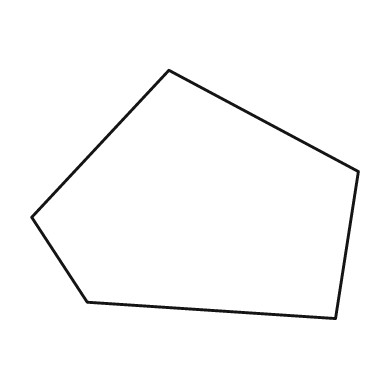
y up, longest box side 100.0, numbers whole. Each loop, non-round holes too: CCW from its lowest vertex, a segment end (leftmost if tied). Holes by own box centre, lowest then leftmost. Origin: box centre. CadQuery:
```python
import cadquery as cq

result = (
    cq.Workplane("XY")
    .moveTo(43.0, -38.0)
    .lineTo(50.0, 7.0)
    .lineTo(-8.0, 38.0)
    .lineTo(-50.0, -7.0)
    .lineTo(-33.0, -33.0)
    .close()
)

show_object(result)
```